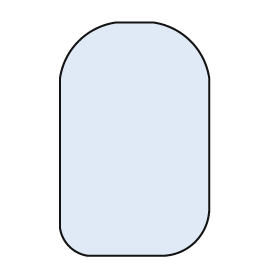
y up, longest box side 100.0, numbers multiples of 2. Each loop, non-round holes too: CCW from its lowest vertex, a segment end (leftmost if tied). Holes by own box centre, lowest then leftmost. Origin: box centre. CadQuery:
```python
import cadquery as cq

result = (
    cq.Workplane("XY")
    .moveTo(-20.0, -50.0)
    .lineTo(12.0, -50.0)
    .threePointArc((26.0, -44.0), (32.0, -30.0))
    .lineTo(32.0, 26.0)
    .threePointArc((24.0, 42.0), (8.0, 50.0))
    .lineTo(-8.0, 50.0)
    .threePointArc((-24.0, 42.0), (-32.0, 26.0))
    .lineTo(-32.0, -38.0)
    .threePointArc((-28.0, -46.0), (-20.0, -50.0))
    .close()
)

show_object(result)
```